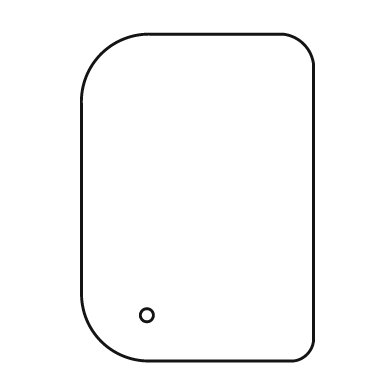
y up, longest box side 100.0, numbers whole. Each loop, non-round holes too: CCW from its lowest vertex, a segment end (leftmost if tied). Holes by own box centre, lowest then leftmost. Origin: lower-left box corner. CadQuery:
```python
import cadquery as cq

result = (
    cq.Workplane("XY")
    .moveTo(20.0, 0.0)
    .lineTo(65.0, 0.0)
    .threePointArc((69.0, 2.0), (71.0, 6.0))
    .lineTo(71.0, 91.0)
    .threePointArc((68.0, 97.0), (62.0, 100.0))
    .lineTo(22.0, 100.0)
    .threePointArc((6.0, 94.0), (0.0, 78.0))
    .lineTo(0.0, 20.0)
    .threePointArc((6.0, 6.0), (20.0, 0.0))
    .close()
    .moveTo(20.0, 14.0)
    .circle(2.0)
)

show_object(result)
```